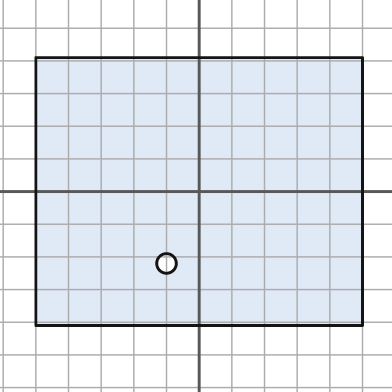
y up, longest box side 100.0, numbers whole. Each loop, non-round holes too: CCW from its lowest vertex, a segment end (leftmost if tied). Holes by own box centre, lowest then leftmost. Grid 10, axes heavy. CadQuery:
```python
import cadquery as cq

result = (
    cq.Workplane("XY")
    .moveTo(-50.0, -41.0)
    .lineTo(50.0, -41.0)
    .lineTo(50.0, 41.0)
    .lineTo(-50.0, 41.0)
    .close()
    .moveTo(-10.0, -22.0)
    .circle(3.0)
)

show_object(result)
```